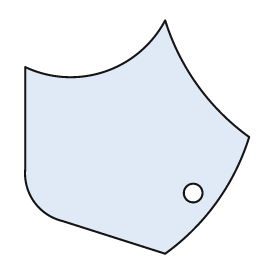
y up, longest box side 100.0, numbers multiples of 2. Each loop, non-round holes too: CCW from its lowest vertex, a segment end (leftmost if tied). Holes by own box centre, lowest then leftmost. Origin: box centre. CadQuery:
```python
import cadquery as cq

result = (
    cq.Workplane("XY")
    .moveTo(12.0, -50.0)
    .threePointArc((34.0, -28.0), (48.0, 0.0))
    .threePointArc((26.0, 22.0), (12.0, 50.0))
    .threePointArc((-14.0, 28.0), (-48.0, 30.0))
    .lineTo(-48.0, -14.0)
    .threePointArc((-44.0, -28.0), (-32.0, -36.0))
    .close()
    .moveTo(24.0, -24.0)
    .circle(4.0)
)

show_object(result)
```